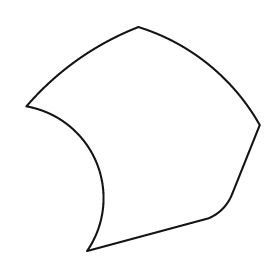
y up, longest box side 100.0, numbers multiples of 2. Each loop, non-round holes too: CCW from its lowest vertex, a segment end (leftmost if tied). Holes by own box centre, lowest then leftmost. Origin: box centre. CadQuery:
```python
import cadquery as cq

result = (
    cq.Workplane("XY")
    .moveTo(-24.0, -48.0)
    .lineTo(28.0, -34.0)
    .threePointArc((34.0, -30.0), (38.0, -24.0))
    .lineTo(50.0, 6.0)
    .threePointArc((28.0, 32.0), (-2.0, 48.0))
    .threePointArc((-28.0, 34.0), (-50.0, 14.0))
    .threePointArc((-20.0, -10.0), (-24.0, -48.0))
    .close()
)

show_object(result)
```